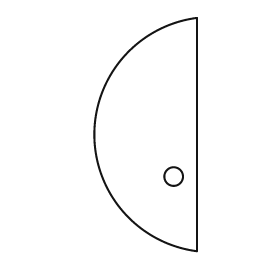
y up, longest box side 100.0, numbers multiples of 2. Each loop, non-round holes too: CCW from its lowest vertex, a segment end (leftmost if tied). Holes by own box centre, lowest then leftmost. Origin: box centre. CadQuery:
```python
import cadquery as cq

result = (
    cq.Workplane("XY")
    .moveTo(22.0, -50.0)
    .lineTo(22.0, 50.0)
    .threePointArc((-22.0, 0.0), (22.0, -50.0))
    .close()
    .moveTo(12.0, -18.0)
    .circle(4.0)
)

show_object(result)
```